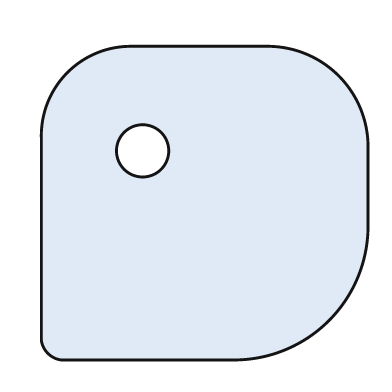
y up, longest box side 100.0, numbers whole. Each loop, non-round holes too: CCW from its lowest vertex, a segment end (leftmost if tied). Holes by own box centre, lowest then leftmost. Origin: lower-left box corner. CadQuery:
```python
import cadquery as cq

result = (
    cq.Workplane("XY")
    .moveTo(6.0, 0.0)
    .lineTo(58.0, 0.0)
    .threePointArc((88.0, 12.0), (100.0, 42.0))
    .lineTo(100.0, 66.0)
    .threePointArc((91.0, 87.0), (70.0, 96.0))
    .lineTo(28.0, 96.0)
    .threePointArc((8.0, 88.0), (0.0, 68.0))
    .lineTo(0.0, 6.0)
    .threePointArc((2.0, 2.0), (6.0, 0.0))
    .close()
    .moveTo(31.0, 64.0)
    .circle(8.0)
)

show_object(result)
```